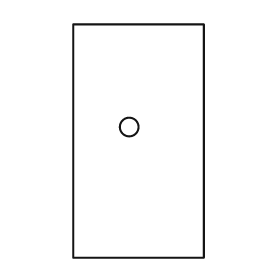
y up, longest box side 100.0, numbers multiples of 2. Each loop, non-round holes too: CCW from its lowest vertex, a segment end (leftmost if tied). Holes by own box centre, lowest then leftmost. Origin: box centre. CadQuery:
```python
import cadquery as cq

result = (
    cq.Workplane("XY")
    .moveTo(-28.0, -50.0)
    .lineTo(28.0, -50.0)
    .lineTo(28.0, 50.0)
    .lineTo(-28.0, 50.0)
    .close()
    .moveTo(-4.0, 6.0)
    .circle(4.0)
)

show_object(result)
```